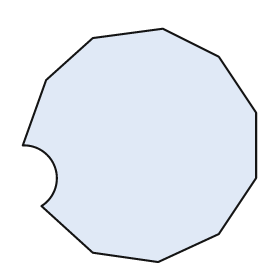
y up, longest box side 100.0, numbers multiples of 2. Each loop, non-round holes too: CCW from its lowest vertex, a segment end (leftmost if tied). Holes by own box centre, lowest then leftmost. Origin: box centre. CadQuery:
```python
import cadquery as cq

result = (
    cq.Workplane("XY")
    .moveTo(8.0, -50.0)
    .lineTo(34.0, -38.0)
    .lineTo(50.0, -14.0)
    .lineTo(50.0, 14.0)
    .lineTo(34.0, 38.0)
    .lineTo(10.0, 50.0)
    .lineTo(-20.0, 46.0)
    .lineTo(-40.0, 28.0)
    .lineTo(-50.0, 0.0)
    .threePointArc((-36.0, -10.0), (-42.0, -26.0))
    .lineTo(-20.0, -46.0)
    .close()
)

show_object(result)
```